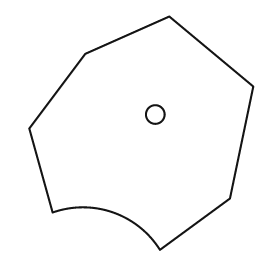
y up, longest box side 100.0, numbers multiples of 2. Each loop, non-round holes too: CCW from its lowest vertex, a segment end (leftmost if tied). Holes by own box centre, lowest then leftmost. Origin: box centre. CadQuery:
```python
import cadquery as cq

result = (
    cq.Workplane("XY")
    .moveTo(8.0, -50.0)
    .lineTo(38.0, -28.0)
    .lineTo(48.0, 20.0)
    .lineTo(12.0, 50.0)
    .lineTo(-24.0, 34.0)
    .lineTo(-48.0, 2.0)
    .lineTo(-38.0, -34.0)
    .threePointArc((-12.0, -34.0), (8.0, -50.0))
    .close()
    .moveTo(6.0, 8.0)
    .circle(4.0)
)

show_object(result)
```